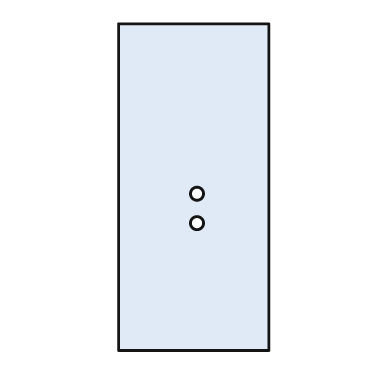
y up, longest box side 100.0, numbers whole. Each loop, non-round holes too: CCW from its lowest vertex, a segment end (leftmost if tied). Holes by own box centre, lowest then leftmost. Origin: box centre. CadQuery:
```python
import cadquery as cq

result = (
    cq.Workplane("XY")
    .moveTo(-23.0, -50.0)
    .lineTo(23.0, -50.0)
    .lineTo(23.0, 50.0)
    .lineTo(-23.0, 50.0)
    .close()
    .moveTo(1.0, -11.0)
    .circle(2.0)
    .moveTo(1.0, -2.0)
    .circle(2.0)
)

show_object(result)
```